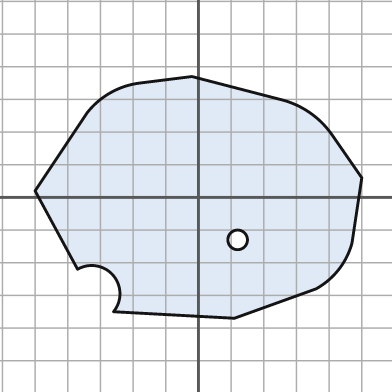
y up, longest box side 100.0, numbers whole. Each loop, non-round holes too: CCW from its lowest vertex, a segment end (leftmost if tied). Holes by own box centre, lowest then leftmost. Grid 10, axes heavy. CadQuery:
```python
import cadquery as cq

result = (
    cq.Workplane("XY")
    .moveTo(11.0, -37.0)
    .lineTo(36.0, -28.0)
    .threePointArc((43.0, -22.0), (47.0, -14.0))
    .lineTo(50.0, 6.0)
    .lineTo(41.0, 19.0)
    .threePointArc((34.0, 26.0), (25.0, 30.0))
    .lineTo(-2.0, 37.0)
    .lineTo(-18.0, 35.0)
    .threePointArc((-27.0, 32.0), (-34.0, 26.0))
    .lineTo(-50.0, 2.0)
    .lineTo(-37.0, -22.0)
    .threePointArc((-26.0, -24.0), (-26.0, -35.0))
    .close()
    .moveTo(12.0, -13.0)
    .circle(3.0)
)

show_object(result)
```